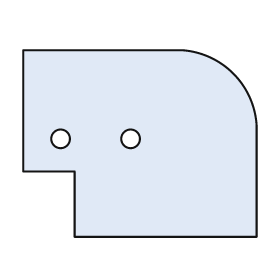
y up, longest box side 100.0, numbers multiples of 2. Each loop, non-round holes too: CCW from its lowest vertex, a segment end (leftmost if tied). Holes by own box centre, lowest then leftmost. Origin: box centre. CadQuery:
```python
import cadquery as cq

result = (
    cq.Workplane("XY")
    .moveTo(-28.0, -40.0)
    .lineTo(50.0, -40.0)
    .lineTo(50.0, 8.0)
    .threePointArc((40.0, 30.0), (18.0, 40.0))
    .lineTo(-50.0, 40.0)
    .lineTo(-50.0, -12.0)
    .lineTo(-28.0, -12.0)
    .close()
    .moveTo(-34.0, 2.0)
    .circle(4.0)
    .moveTo(-4.0, 2.0)
    .circle(4.0)
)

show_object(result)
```